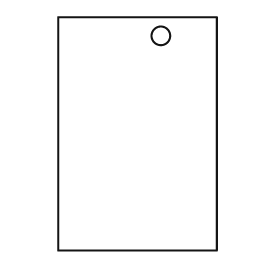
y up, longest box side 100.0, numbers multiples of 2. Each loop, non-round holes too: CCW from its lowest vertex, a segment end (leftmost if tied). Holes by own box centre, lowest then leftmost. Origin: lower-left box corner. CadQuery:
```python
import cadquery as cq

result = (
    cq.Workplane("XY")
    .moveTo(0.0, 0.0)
    .lineTo(68.0, 0.0)
    .lineTo(68.0, 100.0)
    .lineTo(0.0, 100.0)
    .close()
    .moveTo(44.0, 92.0)
    .circle(4.0)
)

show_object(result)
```